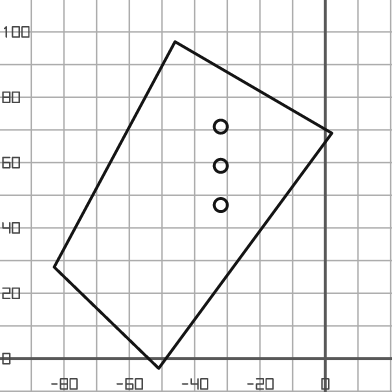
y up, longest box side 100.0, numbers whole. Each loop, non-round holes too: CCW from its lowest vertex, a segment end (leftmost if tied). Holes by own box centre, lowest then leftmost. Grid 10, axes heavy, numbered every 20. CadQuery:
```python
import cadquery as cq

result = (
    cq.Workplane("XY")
    .moveTo(-51.0, -3.0)
    .lineTo(2.0, 69.0)
    .lineTo(-46.0, 97.0)
    .lineTo(-83.0, 28.0)
    .close()
    .moveTo(-32.0, 47.0)
    .circle(2.0)
    .moveTo(-32.0, 59.0)
    .circle(2.0)
    .moveTo(-32.0, 71.0)
    .circle(2.0)
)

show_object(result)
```